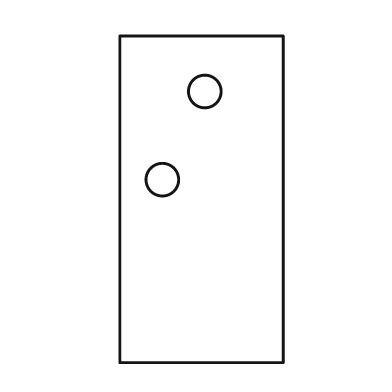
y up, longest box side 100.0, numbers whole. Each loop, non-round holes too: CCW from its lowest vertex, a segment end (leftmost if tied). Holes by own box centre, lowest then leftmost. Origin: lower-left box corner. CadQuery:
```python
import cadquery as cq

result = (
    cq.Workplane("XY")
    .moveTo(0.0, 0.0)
    .lineTo(50.0, 0.0)
    .lineTo(50.0, 100.0)
    .lineTo(0.0, 100.0)
    .close()
    .moveTo(13.0, 56.0)
    .circle(5.0)
    .moveTo(26.0, 83.0)
    .circle(5.0)
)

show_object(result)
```